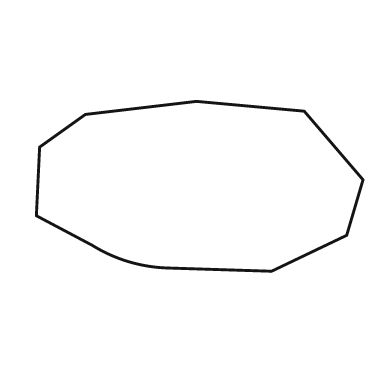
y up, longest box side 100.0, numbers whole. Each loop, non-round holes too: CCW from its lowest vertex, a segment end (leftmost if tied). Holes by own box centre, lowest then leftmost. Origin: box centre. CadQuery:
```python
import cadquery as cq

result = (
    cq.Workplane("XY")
    .moveTo(22.0, -26.0)
    .lineTo(45.0, -15.0)
    .lineTo(50.0, 2.0)
    .lineTo(32.0, 23.0)
    .lineTo(-1.0, 26.0)
    .lineTo(-35.0, 22.0)
    .lineTo(-49.0, 12.0)
    .lineTo(-50.0, -9.0)
    .lineTo(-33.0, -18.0)
    .threePointArc((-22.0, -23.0), (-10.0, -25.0))
    .close()
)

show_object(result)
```